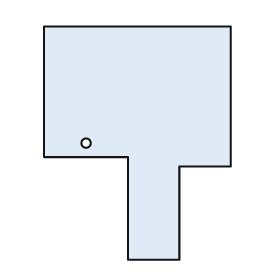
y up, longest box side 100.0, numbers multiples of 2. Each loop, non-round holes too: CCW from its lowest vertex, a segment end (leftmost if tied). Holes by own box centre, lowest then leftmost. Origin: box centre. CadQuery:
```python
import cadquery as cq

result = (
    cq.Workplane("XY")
    .moveTo(-4.0, -50.0)
    .lineTo(18.0, -50.0)
    .lineTo(18.0, -10.0)
    .lineTo(40.0, -10.0)
    .lineTo(40.0, 50.0)
    .lineTo(-40.0, 50.0)
    .lineTo(-40.0, -6.0)
    .lineTo(-4.0, -6.0)
    .close()
    .moveTo(-22.0, 0.0)
    .circle(2.0)
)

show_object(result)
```